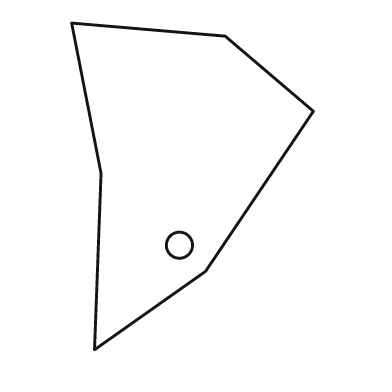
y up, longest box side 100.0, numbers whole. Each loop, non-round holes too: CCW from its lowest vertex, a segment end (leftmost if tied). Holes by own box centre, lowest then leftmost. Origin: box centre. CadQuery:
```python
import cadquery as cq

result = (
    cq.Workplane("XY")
    .moveTo(-30.0, -50.0)
    .lineTo(4.0, -26.0)
    .lineTo(37.0, 23.0)
    .lineTo(10.0, 46.0)
    .lineTo(-37.0, 50.0)
    .lineTo(-28.0, 4.0)
    .close()
    .moveTo(-4.0, -18.0)
    .circle(4.0)
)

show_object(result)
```